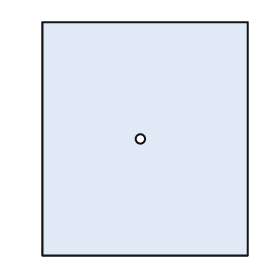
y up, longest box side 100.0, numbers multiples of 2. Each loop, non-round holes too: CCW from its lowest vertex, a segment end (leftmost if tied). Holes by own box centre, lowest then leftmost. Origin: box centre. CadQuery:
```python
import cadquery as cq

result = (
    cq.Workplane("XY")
    .moveTo(-44.0, -50.0)
    .lineTo(44.0, -50.0)
    .lineTo(44.0, 50.0)
    .lineTo(-44.0, 50.0)
    .close()
    .moveTo(-2.0, 0.0)
    .circle(2.0)
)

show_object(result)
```